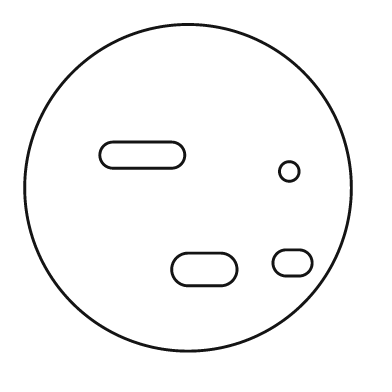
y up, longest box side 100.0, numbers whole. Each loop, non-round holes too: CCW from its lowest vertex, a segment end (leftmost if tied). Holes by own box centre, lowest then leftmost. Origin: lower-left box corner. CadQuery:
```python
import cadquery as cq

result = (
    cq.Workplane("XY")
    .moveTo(50.0, 50.0)
    .circle(50.0)
    .moveTo(50.0, 20.0)
    .lineTo(60.0, 20.0)
    .threePointArc((65.0, 25.0), (60.0, 30.0))
    .lineTo(50.0, 30.0)
    .threePointArc((45.0, 25.0), (50.0, 20.0))
    .close()
    .moveTo(80.0, 23.0)
    .lineTo(84.0, 23.0)
    .threePointArc((88.0, 27.0), (84.0, 31.0))
    .lineTo(80.0, 31.0)
    .threePointArc((76.0, 27.0), (80.0, 23.0))
    .close()
    .moveTo(81.0, 55.0)
    .circle(3.0)
    .moveTo(27.0, 56.0)
    .lineTo(45.0, 56.0)
    .threePointArc((49.0, 60.0), (45.0, 64.0))
    .lineTo(27.0, 64.0)
    .threePointArc((23.0, 60.0), (27.0, 56.0))
    .close()
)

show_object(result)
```